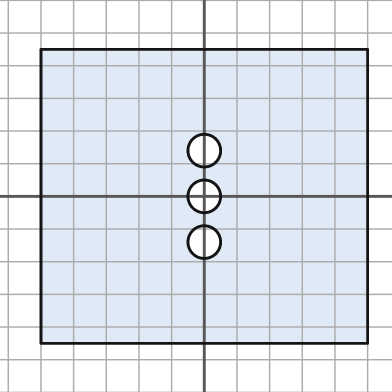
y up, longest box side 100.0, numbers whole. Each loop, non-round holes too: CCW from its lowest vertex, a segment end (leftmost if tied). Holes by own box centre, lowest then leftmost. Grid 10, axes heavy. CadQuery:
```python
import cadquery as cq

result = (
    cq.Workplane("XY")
    .moveTo(-50.0, -45.0)
    .lineTo(50.0, -45.0)
    .lineTo(50.0, 45.0)
    .lineTo(-50.0, 45.0)
    .close()
    .moveTo(0.0, -14.0)
    .circle(5.0)
    .moveTo(0.0, 0.0)
    .circle(5.0)
    .moveTo(0.0, 14.0)
    .circle(5.0)
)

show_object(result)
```